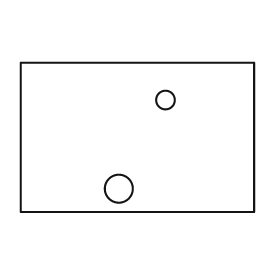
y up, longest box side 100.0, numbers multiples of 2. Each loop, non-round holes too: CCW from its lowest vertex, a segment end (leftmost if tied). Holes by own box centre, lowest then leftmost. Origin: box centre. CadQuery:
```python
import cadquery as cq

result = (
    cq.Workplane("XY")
    .moveTo(-50.0, -32.0)
    .lineTo(50.0, -32.0)
    .lineTo(50.0, 32.0)
    .lineTo(-50.0, 32.0)
    .close()
    .moveTo(-8.0, -22.0)
    .circle(6.0)
    .moveTo(12.0, 16.0)
    .circle(4.0)
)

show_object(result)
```